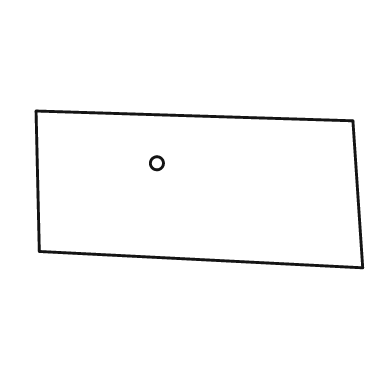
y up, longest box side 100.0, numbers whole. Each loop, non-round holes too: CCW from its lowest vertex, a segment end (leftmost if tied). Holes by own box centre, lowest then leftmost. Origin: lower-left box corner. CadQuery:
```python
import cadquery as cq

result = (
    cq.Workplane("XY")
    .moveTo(100.0, 0.0)
    .lineTo(97.0, 45.0)
    .lineTo(0.0, 48.0)
    .lineTo(1.0, 5.0)
    .close()
    .moveTo(37.0, 32.0)
    .circle(2.0)
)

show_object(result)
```